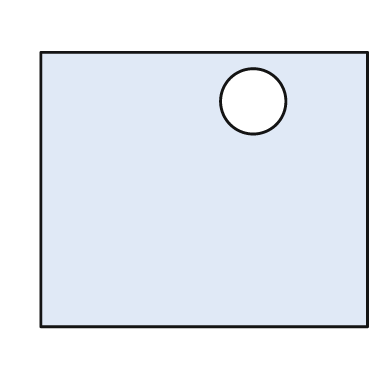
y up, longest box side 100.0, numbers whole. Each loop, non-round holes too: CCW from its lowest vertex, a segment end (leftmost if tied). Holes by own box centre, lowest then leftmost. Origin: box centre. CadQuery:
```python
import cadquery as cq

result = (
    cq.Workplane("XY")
    .moveTo(-50.0, -42.0)
    .lineTo(50.0, -42.0)
    .lineTo(50.0, 42.0)
    .lineTo(-50.0, 42.0)
    .close()
    .moveTo(15.0, 27.0)
    .circle(10.0)
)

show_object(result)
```